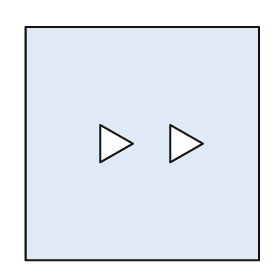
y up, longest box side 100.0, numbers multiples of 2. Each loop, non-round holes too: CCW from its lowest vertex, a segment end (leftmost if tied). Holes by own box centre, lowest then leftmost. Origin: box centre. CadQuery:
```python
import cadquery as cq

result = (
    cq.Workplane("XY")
    .moveTo(-50.0, -50.0)
    .lineTo(50.0, -50.0)
    .lineTo(50.0, 50.0)
    .lineTo(-50.0, 50.0)
    .close()
    .moveTo(-18.0, -8.0)
    .lineTo(-4.0, 0.0)
    .lineTo(-18.0, 8.0)
    .close()
    .moveTo(12.0, -8.0)
    .lineTo(26.0, 0.0)
    .lineTo(12.0, 8.0)
    .close()
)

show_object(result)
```